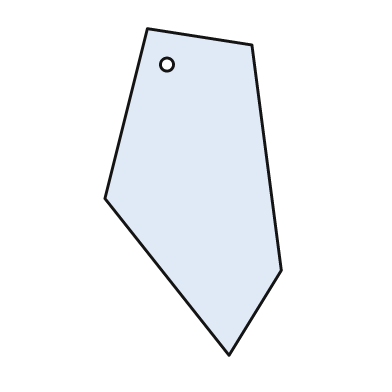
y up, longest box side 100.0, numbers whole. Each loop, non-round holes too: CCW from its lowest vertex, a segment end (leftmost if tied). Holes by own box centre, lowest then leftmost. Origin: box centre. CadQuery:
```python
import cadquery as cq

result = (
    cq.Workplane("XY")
    .moveTo(11.0, -50.0)
    .lineTo(27.0, -24.0)
    .lineTo(18.0, 45.0)
    .lineTo(-14.0, 50.0)
    .lineTo(-27.0, -2.0)
    .close()
    .moveTo(-8.0, 39.0)
    .circle(2.0)
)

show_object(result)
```